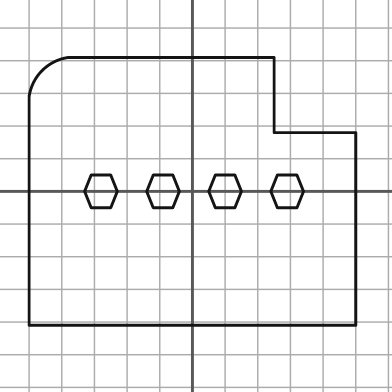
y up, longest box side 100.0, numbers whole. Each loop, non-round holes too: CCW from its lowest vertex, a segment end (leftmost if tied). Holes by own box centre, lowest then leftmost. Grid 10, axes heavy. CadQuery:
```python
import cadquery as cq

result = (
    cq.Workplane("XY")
    .moveTo(-50.0, -41.0)
    .lineTo(50.0, -41.0)
    .lineTo(50.0, 18.0)
    .lineTo(25.0, 18.0)
    .lineTo(25.0, 41.0)
    .lineTo(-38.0, 41.0)
    .threePointArc((-46.0, 37.0), (-50.0, 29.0))
    .close()
    .moveTo(-31.0, -5.0)
    .lineTo(-25.0, -5.0)
    .lineTo(-23.0, 0.0)
    .lineTo(-25.0, 5.0)
    .lineTo(-31.0, 5.0)
    .lineTo(-33.0, 0.0)
    .close()
    .moveTo(-12.0, -5.0)
    .lineTo(-6.0, -5.0)
    .lineTo(-4.0, 0.0)
    .lineTo(-6.0, 5.0)
    .lineTo(-12.0, 5.0)
    .lineTo(-14.0, 0.0)
    .close()
    .moveTo(7.0, -5.0)
    .lineTo(13.0, -5.0)
    .lineTo(15.0, 0.0)
    .lineTo(13.0, 5.0)
    .lineTo(7.0, 5.0)
    .lineTo(5.0, 0.0)
    .close()
    .moveTo(26.0, -5.0)
    .lineTo(32.0, -5.0)
    .lineTo(34.0, 0.0)
    .lineTo(32.0, 5.0)
    .lineTo(26.0, 5.0)
    .lineTo(24.0, 0.0)
    .close()
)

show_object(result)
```